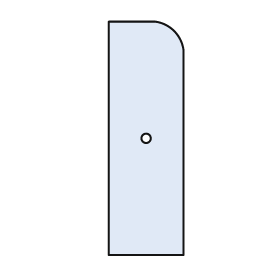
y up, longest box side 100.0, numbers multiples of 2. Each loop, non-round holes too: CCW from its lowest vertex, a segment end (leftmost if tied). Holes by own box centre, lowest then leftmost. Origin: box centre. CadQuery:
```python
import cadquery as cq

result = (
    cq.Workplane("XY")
    .moveTo(-16.0, -50.0)
    .lineTo(16.0, -50.0)
    .lineTo(16.0, 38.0)
    .threePointArc((12.0, 46.0), (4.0, 50.0))
    .lineTo(-16.0, 50.0)
    .close()
    .moveTo(0.0, 0.0)
    .circle(2.0)
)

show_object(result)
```